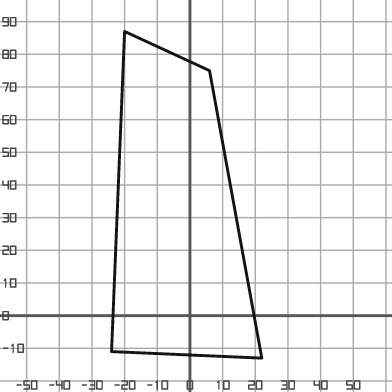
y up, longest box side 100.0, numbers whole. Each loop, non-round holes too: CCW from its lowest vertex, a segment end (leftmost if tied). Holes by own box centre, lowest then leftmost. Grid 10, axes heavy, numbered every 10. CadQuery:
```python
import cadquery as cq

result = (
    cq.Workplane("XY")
    .moveTo(22.0, -13.0)
    .lineTo(6.0, 75.0)
    .lineTo(-20.0, 87.0)
    .lineTo(-24.0, -11.0)
    .close()
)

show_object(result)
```